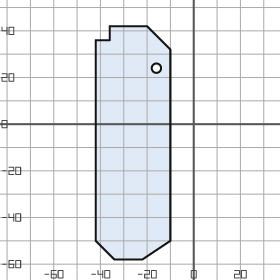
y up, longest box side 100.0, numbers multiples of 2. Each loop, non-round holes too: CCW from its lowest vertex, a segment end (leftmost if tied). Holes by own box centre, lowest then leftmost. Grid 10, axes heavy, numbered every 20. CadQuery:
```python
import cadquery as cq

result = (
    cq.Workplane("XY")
    .moveTo(-34.0, -58.0)
    .lineTo(-22.0, -58.0)
    .lineTo(-10.0, -50.0)
    .lineTo(-10.0, 32.0)
    .lineTo(-20.0, 42.0)
    .lineTo(-36.0, 42.0)
    .lineTo(-36.0, 36.0)
    .lineTo(-42.0, 36.0)
    .lineTo(-42.0, -50.0)
    .close()
    .moveTo(-16.0, 24.0)
    .circle(2.0)
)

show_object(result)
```